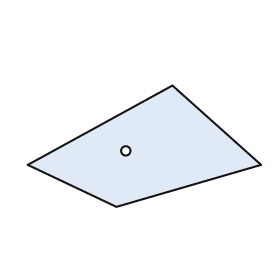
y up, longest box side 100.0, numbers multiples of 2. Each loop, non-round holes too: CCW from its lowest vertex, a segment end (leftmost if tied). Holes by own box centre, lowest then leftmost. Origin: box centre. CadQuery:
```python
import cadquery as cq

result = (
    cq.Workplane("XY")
    .moveTo(-12.0, -26.0)
    .lineTo(50.0, -8.0)
    .lineTo(12.0, 26.0)
    .lineTo(-50.0, -8.0)
    .close()
    .moveTo(-8.0, -2.0)
    .circle(2.0)
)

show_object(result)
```